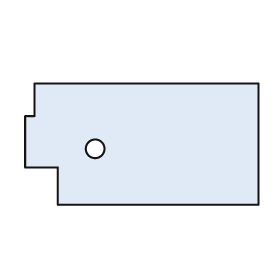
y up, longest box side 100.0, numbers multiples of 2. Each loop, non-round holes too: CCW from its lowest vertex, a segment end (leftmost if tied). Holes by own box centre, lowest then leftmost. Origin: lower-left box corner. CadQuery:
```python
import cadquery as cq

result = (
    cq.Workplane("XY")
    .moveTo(14.0, 0.0)
    .lineTo(100.0, 0.0)
    .lineTo(100.0, 52.0)
    .lineTo(4.0, 52.0)
    .lineTo(4.0, 38.0)
    .lineTo(0.0, 38.0)
    .lineTo(0.0, 16.0)
    .lineTo(14.0, 16.0)
    .close()
    .moveTo(30.0, 24.0)
    .circle(4.0)
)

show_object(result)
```